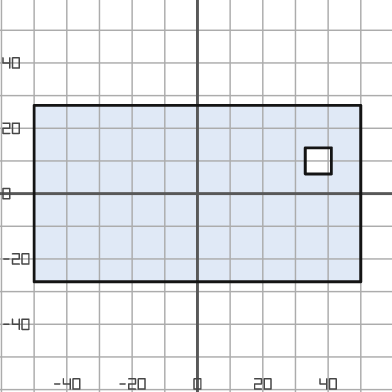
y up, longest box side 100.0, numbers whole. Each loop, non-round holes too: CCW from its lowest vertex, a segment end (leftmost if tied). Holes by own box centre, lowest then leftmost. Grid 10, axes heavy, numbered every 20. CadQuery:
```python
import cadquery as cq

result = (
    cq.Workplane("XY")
    .moveTo(-50.0, -27.0)
    .lineTo(50.0, -27.0)
    .lineTo(50.0, 27.0)
    .lineTo(-50.0, 27.0)
    .close()
    .moveTo(33.0, 6.0)
    .lineTo(41.0, 6.0)
    .lineTo(41.0, 14.0)
    .lineTo(33.0, 14.0)
    .close()
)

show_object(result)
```